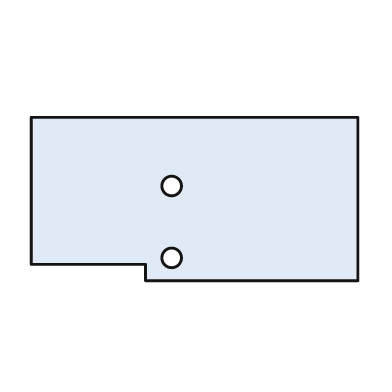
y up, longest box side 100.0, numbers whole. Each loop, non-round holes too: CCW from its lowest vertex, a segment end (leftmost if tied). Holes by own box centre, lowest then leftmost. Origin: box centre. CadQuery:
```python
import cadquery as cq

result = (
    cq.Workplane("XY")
    .moveTo(-15.0, -25.0)
    .lineTo(50.0, -25.0)
    .lineTo(50.0, 25.0)
    .lineTo(-50.0, 25.0)
    .lineTo(-50.0, -20.0)
    .lineTo(-15.0, -20.0)
    .close()
    .moveTo(-7.0, -18.0)
    .circle(3.0)
    .moveTo(-7.0, 4.0)
    .circle(3.0)
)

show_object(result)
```